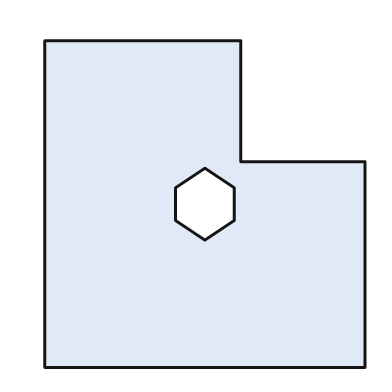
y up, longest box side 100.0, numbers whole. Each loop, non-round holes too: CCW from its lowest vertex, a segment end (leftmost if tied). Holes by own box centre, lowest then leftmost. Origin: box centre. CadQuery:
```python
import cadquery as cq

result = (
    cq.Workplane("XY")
    .moveTo(-49.0, -50.0)
    .lineTo(49.0, -50.0)
    .lineTo(49.0, 13.0)
    .lineTo(11.0, 13.0)
    .lineTo(11.0, 50.0)
    .lineTo(-49.0, 50.0)
    .close()
    .moveTo(0.0, -11.0)
    .lineTo(9.0, -5.0)
    .lineTo(9.0, 5.0)
    .lineTo(0.0, 11.0)
    .lineTo(-9.0, 5.0)
    .lineTo(-9.0, -5.0)
    .close()
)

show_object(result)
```